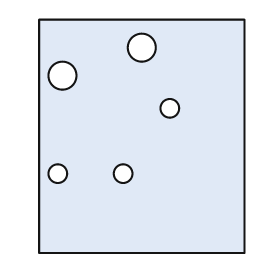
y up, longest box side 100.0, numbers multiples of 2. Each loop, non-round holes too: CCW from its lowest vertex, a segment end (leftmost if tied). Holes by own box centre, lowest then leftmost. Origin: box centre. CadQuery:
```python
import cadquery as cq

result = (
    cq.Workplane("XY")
    .moveTo(-44.0, -50.0)
    .lineTo(44.0, -50.0)
    .lineTo(44.0, 50.0)
    .lineTo(-44.0, 50.0)
    .close()
    .moveTo(-36.0, -16.0)
    .circle(4.0)
    .moveTo(-8.0, -16.0)
    .circle(4.0)
    .moveTo(12.0, 12.0)
    .circle(4.0)
    .moveTo(-34.0, 26.0)
    .circle(6.0)
    .moveTo(0.0, 38.0)
    .circle(6.0)
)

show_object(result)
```